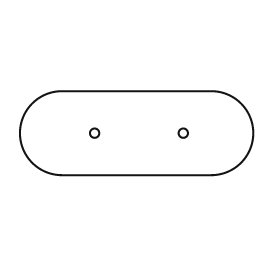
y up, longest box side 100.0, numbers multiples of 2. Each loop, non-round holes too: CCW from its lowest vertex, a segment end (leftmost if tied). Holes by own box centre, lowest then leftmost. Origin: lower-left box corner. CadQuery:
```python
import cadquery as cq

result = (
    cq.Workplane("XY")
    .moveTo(18.0, 0.0)
    .lineTo(82.0, 0.0)
    .threePointArc((100.0, 18.0), (82.0, 36.0))
    .lineTo(18.0, 36.0)
    .threePointArc((0.0, 18.0), (18.0, 0.0))
    .close()
    .moveTo(32.0, 18.0)
    .circle(2.0)
    .moveTo(70.0, 18.0)
    .circle(2.0)
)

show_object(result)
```